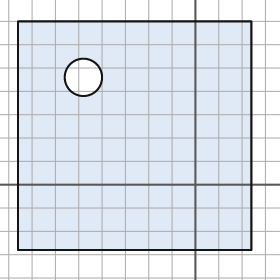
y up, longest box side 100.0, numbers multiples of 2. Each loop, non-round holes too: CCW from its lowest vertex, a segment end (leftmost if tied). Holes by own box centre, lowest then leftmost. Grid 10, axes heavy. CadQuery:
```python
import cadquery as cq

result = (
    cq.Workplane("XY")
    .moveTo(-76.0, -28.0)
    .lineTo(24.0, -28.0)
    .lineTo(24.0, 70.0)
    .lineTo(-76.0, 70.0)
    .close()
    .moveTo(-48.0, 46.0)
    .circle(8.0)
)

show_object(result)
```